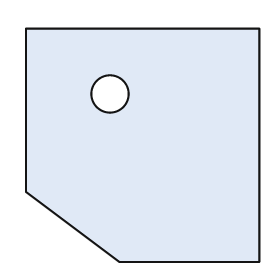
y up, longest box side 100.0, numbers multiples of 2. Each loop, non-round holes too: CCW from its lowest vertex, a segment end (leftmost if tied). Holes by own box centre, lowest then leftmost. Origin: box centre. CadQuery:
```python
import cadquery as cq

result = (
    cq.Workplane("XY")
    .moveTo(-10.0, -50.0)
    .lineTo(50.0, -50.0)
    .lineTo(50.0, 50.0)
    .lineTo(-50.0, 50.0)
    .lineTo(-50.0, -20.0)
    .close()
    .moveTo(-14.0, 22.0)
    .circle(8.0)
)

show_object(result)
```